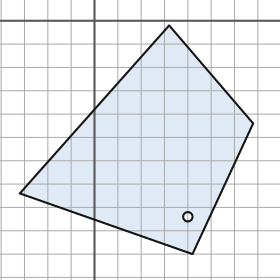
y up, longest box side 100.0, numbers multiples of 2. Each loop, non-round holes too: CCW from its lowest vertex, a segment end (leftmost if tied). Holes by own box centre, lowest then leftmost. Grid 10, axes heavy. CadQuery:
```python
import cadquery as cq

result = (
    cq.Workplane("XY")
    .moveTo(42.0, -100.0)
    .lineTo(68.0, -44.0)
    .lineTo(32.0, -2.0)
    .lineTo(-32.0, -74.0)
    .close()
    .moveTo(40.0, -84.0)
    .circle(2.0)
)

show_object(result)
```